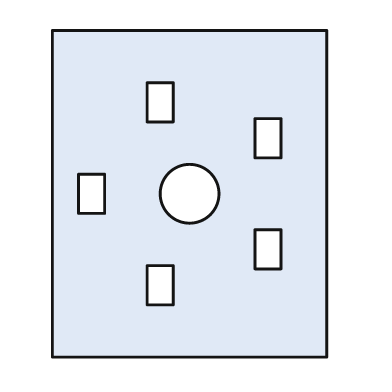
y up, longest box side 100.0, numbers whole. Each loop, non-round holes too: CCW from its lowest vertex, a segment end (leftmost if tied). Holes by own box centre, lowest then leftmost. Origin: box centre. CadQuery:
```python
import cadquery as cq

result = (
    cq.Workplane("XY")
    .moveTo(-42.0, -50.0)
    .lineTo(42.0, -50.0)
    .lineTo(42.0, 50.0)
    .lineTo(-42.0, 50.0)
    .close()
    .moveTo(-13.0, -34.0)
    .lineTo(-5.0, -34.0)
    .lineTo(-5.0, -22.0)
    .lineTo(-13.0, -22.0)
    .close()
    .moveTo(20.0, -23.0)
    .lineTo(28.0, -23.0)
    .lineTo(28.0, -11.0)
    .lineTo(20.0, -11.0)
    .close()
    .moveTo(-34.0, -6.0)
    .lineTo(-26.0, -6.0)
    .lineTo(-26.0, 6.0)
    .lineTo(-34.0, 6.0)
    .close()
    .moveTo(0.0, 0.0)
    .circle(9.0)
    .moveTo(20.0, 11.0)
    .lineTo(28.0, 11.0)
    .lineTo(28.0, 23.0)
    .lineTo(20.0, 23.0)
    .close()
    .moveTo(-13.0, 22.0)
    .lineTo(-5.0, 22.0)
    .lineTo(-5.0, 34.0)
    .lineTo(-13.0, 34.0)
    .close()
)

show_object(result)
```